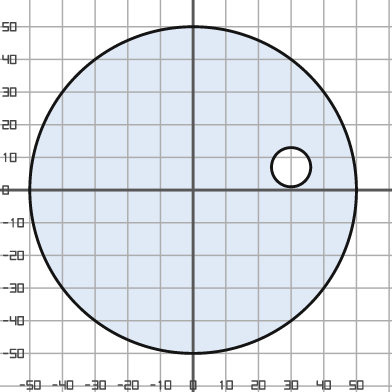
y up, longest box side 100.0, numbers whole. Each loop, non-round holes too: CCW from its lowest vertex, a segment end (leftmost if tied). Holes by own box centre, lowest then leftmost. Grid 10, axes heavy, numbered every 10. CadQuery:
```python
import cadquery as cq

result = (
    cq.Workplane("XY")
    .moveTo(0.0, 0.0)
    .circle(50.0)
    .moveTo(30.0, 7.0)
    .circle(6.0)
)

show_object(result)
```